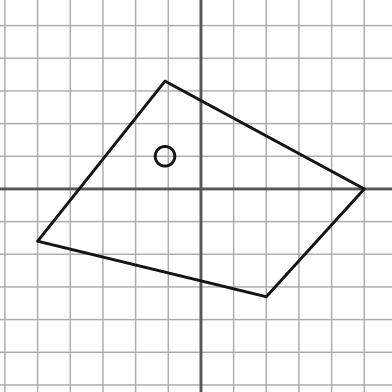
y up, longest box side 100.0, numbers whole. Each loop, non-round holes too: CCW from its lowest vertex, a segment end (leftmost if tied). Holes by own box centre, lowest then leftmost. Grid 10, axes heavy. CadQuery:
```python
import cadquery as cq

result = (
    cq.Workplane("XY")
    .moveTo(20.0, -33.0)
    .lineTo(50.0, 0.0)
    .lineTo(-11.0, 33.0)
    .lineTo(-50.0, -16.0)
    .close()
    .moveTo(-11.0, 10.0)
    .circle(3.0)
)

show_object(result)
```